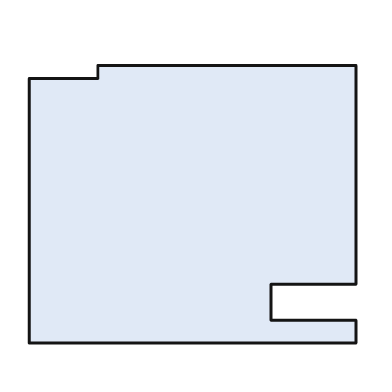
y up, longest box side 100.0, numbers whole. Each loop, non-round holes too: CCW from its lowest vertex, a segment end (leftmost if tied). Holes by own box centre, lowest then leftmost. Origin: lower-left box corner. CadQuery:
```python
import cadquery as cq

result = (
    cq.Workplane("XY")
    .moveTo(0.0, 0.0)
    .lineTo(100.0, 0.0)
    .lineTo(100.0, 7.0)
    .lineTo(74.0, 7.0)
    .lineTo(74.0, 18.0)
    .lineTo(100.0, 18.0)
    .lineTo(100.0, 85.0)
    .lineTo(21.0, 85.0)
    .lineTo(21.0, 81.0)
    .lineTo(0.0, 81.0)
    .close()
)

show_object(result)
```